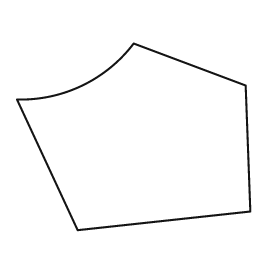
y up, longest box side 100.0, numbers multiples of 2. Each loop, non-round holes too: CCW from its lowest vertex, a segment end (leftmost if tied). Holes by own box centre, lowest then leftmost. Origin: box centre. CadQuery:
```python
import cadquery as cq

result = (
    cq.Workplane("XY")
    .moveTo(-24.0, -40.0)
    .lineTo(50.0, -32.0)
    .lineTo(48.0, 22.0)
    .lineTo(0.0, 40.0)
    .threePointArc((-22.0, 22.0), (-50.0, 16.0))
    .close()
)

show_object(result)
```